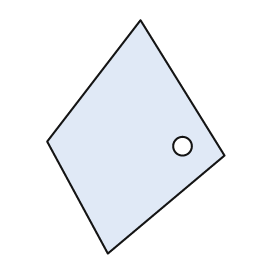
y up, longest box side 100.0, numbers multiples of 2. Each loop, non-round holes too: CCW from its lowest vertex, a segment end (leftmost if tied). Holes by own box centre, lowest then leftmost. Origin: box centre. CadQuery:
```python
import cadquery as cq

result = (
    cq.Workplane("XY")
    .moveTo(-12.0, -50.0)
    .lineTo(38.0, -8.0)
    .lineTo(2.0, 50.0)
    .lineTo(-38.0, -2.0)
    .close()
    .moveTo(20.0, -4.0)
    .circle(4.0)
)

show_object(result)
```